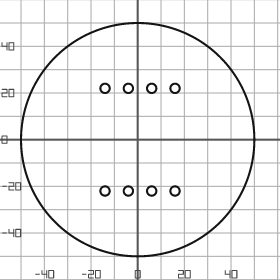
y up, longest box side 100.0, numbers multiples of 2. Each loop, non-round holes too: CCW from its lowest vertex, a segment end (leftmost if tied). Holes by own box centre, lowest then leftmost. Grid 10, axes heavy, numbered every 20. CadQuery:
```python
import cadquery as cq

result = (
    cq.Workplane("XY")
    .moveTo(0.0, 0.0)
    .circle(50.0)
    .moveTo(-14.0, -22.0)
    .circle(2.0)
    .moveTo(-4.0, -22.0)
    .circle(2.0)
    .moveTo(6.0, -22.0)
    .circle(2.0)
    .moveTo(16.0, -22.0)
    .circle(2.0)
    .moveTo(-14.0, 22.0)
    .circle(2.0)
    .moveTo(-4.0, 22.0)
    .circle(2.0)
    .moveTo(6.0, 22.0)
    .circle(2.0)
    .moveTo(16.0, 22.0)
    .circle(2.0)
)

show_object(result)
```